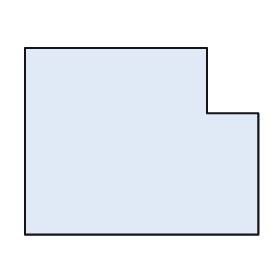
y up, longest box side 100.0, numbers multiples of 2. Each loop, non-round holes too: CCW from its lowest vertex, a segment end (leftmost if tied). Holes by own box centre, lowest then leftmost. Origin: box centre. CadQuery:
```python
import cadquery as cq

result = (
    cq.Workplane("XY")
    .moveTo(-50.0, -40.0)
    .lineTo(50.0, -40.0)
    .lineTo(50.0, 12.0)
    .lineTo(28.0, 12.0)
    .lineTo(28.0, 40.0)
    .lineTo(-50.0, 40.0)
    .close()
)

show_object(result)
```